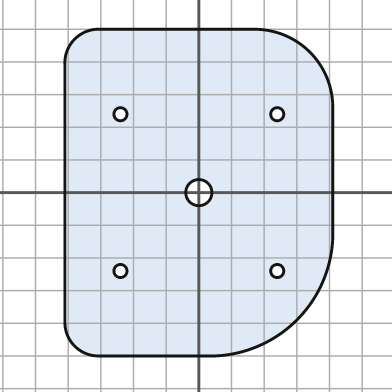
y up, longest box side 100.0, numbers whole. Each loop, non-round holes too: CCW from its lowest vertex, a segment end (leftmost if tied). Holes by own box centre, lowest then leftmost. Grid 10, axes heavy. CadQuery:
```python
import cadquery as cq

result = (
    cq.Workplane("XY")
    .moveTo(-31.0, -50.0)
    .lineTo(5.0, -50.0)
    .threePointArc((30.0, -39.0), (41.0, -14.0))
    .lineTo(41.0, 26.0)
    .threePointArc((34.0, 43.0), (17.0, 50.0))
    .lineTo(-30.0, 50.0)
    .threePointArc((-38.0, 47.0), (-41.0, 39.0))
    .lineTo(-41.0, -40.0)
    .threePointArc((-38.0, -47.0), (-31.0, -50.0))
    .close()
    .moveTo(-24.0, -24.0)
    .circle(2.0)
    .moveTo(24.0, -24.0)
    .circle(2.0)
    .moveTo(0.0, 0.0)
    .circle(4.0)
    .moveTo(-24.0, 24.0)
    .circle(2.0)
    .moveTo(24.0, 24.0)
    .circle(2.0)
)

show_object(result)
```